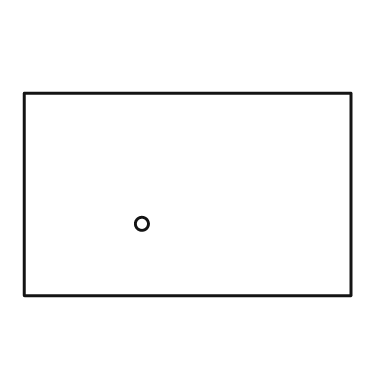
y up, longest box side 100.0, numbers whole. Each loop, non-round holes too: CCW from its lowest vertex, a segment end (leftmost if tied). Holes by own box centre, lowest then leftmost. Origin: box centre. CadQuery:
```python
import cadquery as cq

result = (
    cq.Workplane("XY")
    .moveTo(-50.0, -31.0)
    .lineTo(50.0, -31.0)
    .lineTo(50.0, 31.0)
    .lineTo(-50.0, 31.0)
    .close()
    .moveTo(-14.0, -9.0)
    .circle(2.0)
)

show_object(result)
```